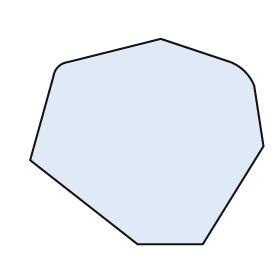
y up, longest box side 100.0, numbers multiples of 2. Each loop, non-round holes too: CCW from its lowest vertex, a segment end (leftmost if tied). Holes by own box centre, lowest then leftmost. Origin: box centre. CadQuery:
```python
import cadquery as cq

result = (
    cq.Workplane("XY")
    .moveTo(-4.0, -44.0)
    .lineTo(24.0, -44.0)
    .lineTo(50.0, -2.0)
    .lineTo(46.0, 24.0)
    .threePointArc((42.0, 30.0), (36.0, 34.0))
    .lineTo(6.0, 44.0)
    .lineTo(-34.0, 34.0)
    .threePointArc((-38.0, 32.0), (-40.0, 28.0))
    .lineTo(-50.0, -8.0)
    .close()
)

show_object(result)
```